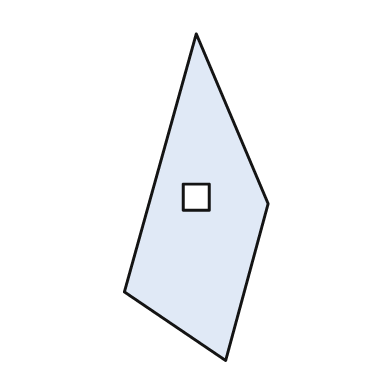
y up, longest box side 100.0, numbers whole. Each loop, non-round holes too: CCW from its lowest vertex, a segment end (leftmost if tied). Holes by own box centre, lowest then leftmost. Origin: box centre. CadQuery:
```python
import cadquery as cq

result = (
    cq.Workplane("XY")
    .moveTo(9.0, -50.0)
    .lineTo(22.0, -2.0)
    .lineTo(0.0, 50.0)
    .lineTo(-22.0, -29.0)
    .close()
    .moveTo(-4.0, -4.0)
    .lineTo(4.0, -4.0)
    .lineTo(4.0, 4.0)
    .lineTo(-4.0, 4.0)
    .close()
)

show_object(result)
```